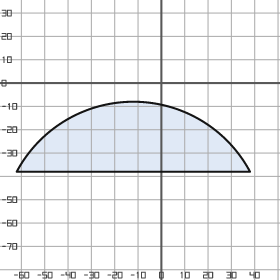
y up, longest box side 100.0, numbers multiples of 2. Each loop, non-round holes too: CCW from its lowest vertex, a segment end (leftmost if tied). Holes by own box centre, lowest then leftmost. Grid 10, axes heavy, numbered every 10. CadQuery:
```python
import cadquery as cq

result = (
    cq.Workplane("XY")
    .moveTo(-62.0, -38.0)
    .lineTo(38.0, -38.0)
    .threePointArc((-12.0, -8.0), (-62.0, -38.0))
    .close()
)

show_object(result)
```